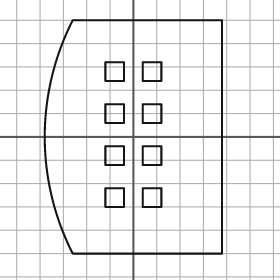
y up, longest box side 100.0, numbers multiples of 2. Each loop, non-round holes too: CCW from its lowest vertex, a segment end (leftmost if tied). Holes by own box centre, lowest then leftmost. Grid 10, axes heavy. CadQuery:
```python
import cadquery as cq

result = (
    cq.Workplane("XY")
    .moveTo(-26.0, -50.0)
    .lineTo(38.0, -50.0)
    .lineTo(38.0, 50.0)
    .lineTo(-26.0, 50.0)
    .threePointArc((-38.0, 0.0), (-26.0, -50.0))
    .close()
    .moveTo(-12.0, -30.0)
    .lineTo(-4.0, -30.0)
    .lineTo(-4.0, -22.0)
    .lineTo(-12.0, -22.0)
    .close()
    .moveTo(4.0, -30.0)
    .lineTo(12.0, -30.0)
    .lineTo(12.0, -22.0)
    .lineTo(4.0, -22.0)
    .close()
    .moveTo(-12.0, -12.0)
    .lineTo(-4.0, -12.0)
    .lineTo(-4.0, -4.0)
    .lineTo(-12.0, -4.0)
    .close()
    .moveTo(4.0, -12.0)
    .lineTo(12.0, -12.0)
    .lineTo(12.0, -4.0)
    .lineTo(4.0, -4.0)
    .close()
    .moveTo(-12.0, 6.0)
    .lineTo(-4.0, 6.0)
    .lineTo(-4.0, 14.0)
    .lineTo(-12.0, 14.0)
    .close()
    .moveTo(4.0, 6.0)
    .lineTo(12.0, 6.0)
    .lineTo(12.0, 14.0)
    .lineTo(4.0, 14.0)
    .close()
    .moveTo(-12.0, 24.0)
    .lineTo(-4.0, 24.0)
    .lineTo(-4.0, 32.0)
    .lineTo(-12.0, 32.0)
    .close()
    .moveTo(4.0, 24.0)
    .lineTo(12.0, 24.0)
    .lineTo(12.0, 32.0)
    .lineTo(4.0, 32.0)
    .close()
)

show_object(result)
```